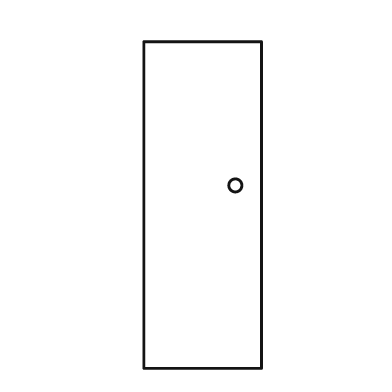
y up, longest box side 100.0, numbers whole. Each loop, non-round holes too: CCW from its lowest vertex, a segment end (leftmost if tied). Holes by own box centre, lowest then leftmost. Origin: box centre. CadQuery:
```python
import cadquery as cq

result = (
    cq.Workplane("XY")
    .moveTo(-18.0, -50.0)
    .lineTo(18.0, -50.0)
    .lineTo(18.0, 50.0)
    .lineTo(-18.0, 50.0)
    .close()
    .moveTo(10.0, 6.0)
    .circle(2.0)
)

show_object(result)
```